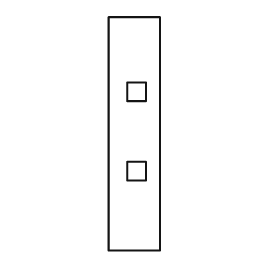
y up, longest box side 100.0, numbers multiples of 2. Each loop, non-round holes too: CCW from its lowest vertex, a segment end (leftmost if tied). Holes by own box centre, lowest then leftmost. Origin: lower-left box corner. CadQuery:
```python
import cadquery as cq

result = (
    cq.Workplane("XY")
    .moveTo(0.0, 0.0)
    .lineTo(22.0, 0.0)
    .lineTo(22.0, 100.0)
    .lineTo(0.0, 100.0)
    .close()
    .moveTo(8.0, 30.0)
    .lineTo(16.0, 30.0)
    .lineTo(16.0, 38.0)
    .lineTo(8.0, 38.0)
    .close()
    .moveTo(8.0, 64.0)
    .lineTo(16.0, 64.0)
    .lineTo(16.0, 72.0)
    .lineTo(8.0, 72.0)
    .close()
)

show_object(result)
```